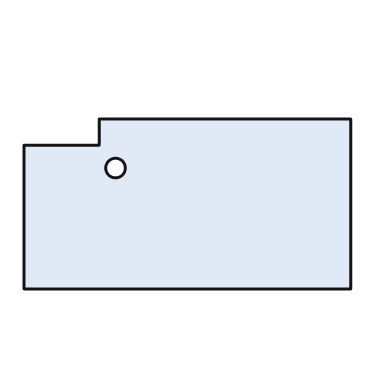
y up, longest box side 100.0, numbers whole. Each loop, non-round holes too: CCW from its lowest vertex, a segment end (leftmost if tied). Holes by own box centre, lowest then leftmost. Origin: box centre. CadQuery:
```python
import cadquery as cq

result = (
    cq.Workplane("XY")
    .moveTo(-50.0, -26.0)
    .lineTo(50.0, -26.0)
    .lineTo(50.0, 26.0)
    .lineTo(-27.0, 26.0)
    .lineTo(-27.0, 18.0)
    .lineTo(-50.0, 18.0)
    .close()
    .moveTo(-22.0, 11.0)
    .circle(3.0)
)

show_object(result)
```